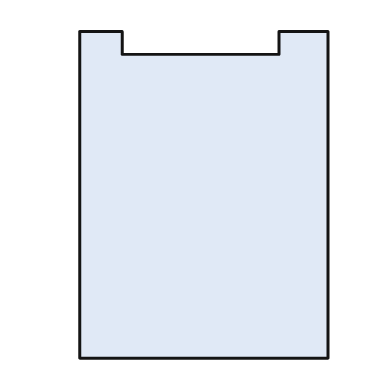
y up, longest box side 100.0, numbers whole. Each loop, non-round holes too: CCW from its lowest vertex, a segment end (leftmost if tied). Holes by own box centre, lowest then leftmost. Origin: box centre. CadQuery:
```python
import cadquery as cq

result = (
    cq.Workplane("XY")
    .moveTo(-38.0, -50.0)
    .lineTo(38.0, -50.0)
    .lineTo(38.0, 50.0)
    .lineTo(23.0, 50.0)
    .lineTo(23.0, 43.0)
    .lineTo(-25.0, 43.0)
    .lineTo(-25.0, 50.0)
    .lineTo(-38.0, 50.0)
    .close()
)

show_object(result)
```